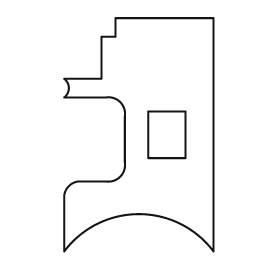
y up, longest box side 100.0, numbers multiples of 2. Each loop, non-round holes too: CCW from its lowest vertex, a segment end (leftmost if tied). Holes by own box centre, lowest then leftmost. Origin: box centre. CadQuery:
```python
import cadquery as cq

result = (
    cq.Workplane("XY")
    .moveTo(-32.0, -50.0)
    .threePointArc((0.0, -34.0), (32.0, -50.0))
    .lineTo(32.0, 50.0)
    .lineTo(-10.0, 50.0)
    .lineTo(-10.0, 42.0)
    .lineTo(-16.0, 42.0)
    .lineTo(-16.0, 24.0)
    .lineTo(-32.0, 24.0)
    .threePointArc((-30.0, 20.0), (-32.0, 16.0))
    .lineTo(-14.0, 16.0)
    .threePointArc((-8.0, 14.0), (-6.0, 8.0))
    .lineTo(-6.0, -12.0)
    .threePointArc((-8.0, -18.0), (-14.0, -20.0))
    .lineTo(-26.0, -20.0)
    .threePointArc((-30.0, -22.0), (-32.0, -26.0))
    .close()
    .moveTo(4.0, -10.0)
    .lineTo(20.0, -10.0)
    .lineTo(20.0, 10.0)
    .lineTo(4.0, 10.0)
    .close()
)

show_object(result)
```